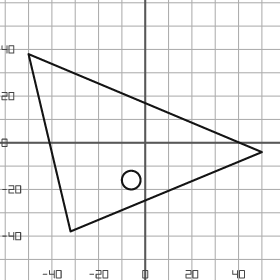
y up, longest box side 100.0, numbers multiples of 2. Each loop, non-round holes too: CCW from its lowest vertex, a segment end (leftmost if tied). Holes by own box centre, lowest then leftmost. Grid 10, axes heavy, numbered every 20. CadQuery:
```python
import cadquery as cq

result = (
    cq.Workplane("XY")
    .moveTo(-32.0, -38.0)
    .lineTo(50.0, -4.0)
    .lineTo(-50.0, 38.0)
    .close()
    .moveTo(-6.0, -16.0)
    .circle(4.0)
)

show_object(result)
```